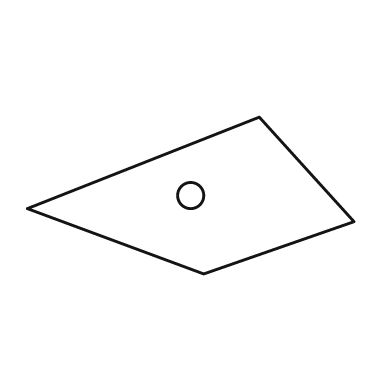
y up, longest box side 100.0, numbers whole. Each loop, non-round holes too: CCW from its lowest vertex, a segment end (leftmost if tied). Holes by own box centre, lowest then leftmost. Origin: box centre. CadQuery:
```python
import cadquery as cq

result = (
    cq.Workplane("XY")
    .moveTo(4.0, -24.0)
    .lineTo(50.0, -8.0)
    .lineTo(21.0, 24.0)
    .lineTo(-50.0, -4.0)
    .close()
    .moveTo(0.0, 0.0)
    .circle(4.0)
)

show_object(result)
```